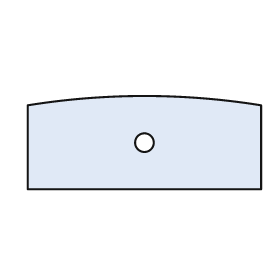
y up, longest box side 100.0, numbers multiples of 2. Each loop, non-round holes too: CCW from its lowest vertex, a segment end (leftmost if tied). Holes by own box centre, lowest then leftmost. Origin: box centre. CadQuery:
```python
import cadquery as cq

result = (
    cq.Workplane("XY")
    .moveTo(-50.0, -20.0)
    .lineTo(50.0, -20.0)
    .lineTo(50.0, 16.0)
    .threePointArc((0.0, 20.0), (-50.0, 16.0))
    .close()
    .moveTo(0.0, 0.0)
    .circle(4.0)
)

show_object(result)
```